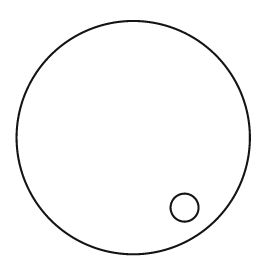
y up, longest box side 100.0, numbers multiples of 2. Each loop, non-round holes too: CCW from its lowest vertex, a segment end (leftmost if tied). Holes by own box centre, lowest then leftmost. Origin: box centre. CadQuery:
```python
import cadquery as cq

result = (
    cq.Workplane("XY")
    .moveTo(0.0, 0.0)
    .circle(50.0)
    .moveTo(22.0, -30.0)
    .circle(6.0)
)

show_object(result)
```